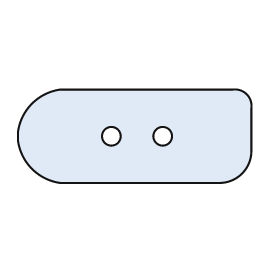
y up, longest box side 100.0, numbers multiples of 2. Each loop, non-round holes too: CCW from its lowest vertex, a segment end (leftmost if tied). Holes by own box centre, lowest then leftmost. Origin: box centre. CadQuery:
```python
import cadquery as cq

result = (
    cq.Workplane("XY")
    .moveTo(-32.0, -20.0)
    .lineTo(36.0, -20.0)
    .threePointArc((46.0, -16.0), (50.0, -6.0))
    .lineTo(50.0, 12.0)
    .threePointArc((48.0, 18.0), (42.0, 20.0))
    .lineTo(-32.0, 20.0)
    .threePointArc((-44.0, 14.0), (-50.0, 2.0))
    .lineTo(-50.0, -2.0)
    .threePointArc((-44.0, -14.0), (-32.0, -20.0))
    .close()
    .moveTo(-10.0, 0.0)
    .circle(4.0)
    .moveTo(12.0, 0.0)
    .circle(4.0)
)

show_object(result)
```